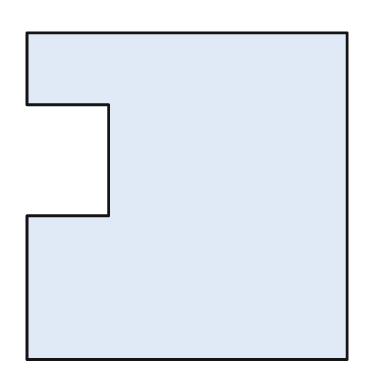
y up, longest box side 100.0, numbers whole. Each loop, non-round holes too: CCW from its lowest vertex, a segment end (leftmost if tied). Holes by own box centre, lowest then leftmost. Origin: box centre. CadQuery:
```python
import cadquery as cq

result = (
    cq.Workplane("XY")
    .moveTo(-49.0, -50.0)
    .lineTo(49.0, -50.0)
    .lineTo(49.0, 50.0)
    .lineTo(-49.0, 50.0)
    .lineTo(-49.0, 28.0)
    .lineTo(-24.0, 28.0)
    .lineTo(-24.0, -6.0)
    .lineTo(-49.0, -6.0)
    .close()
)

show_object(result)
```